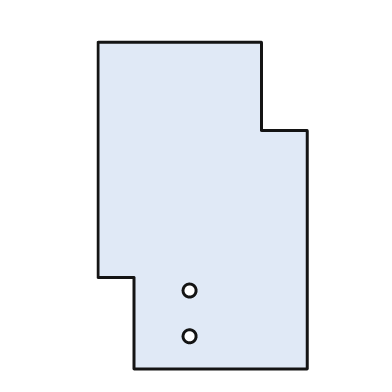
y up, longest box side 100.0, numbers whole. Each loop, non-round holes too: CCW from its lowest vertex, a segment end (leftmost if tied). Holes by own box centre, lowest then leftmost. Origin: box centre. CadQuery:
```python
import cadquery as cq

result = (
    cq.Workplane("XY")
    .moveTo(-21.0, -50.0)
    .lineTo(32.0, -50.0)
    .lineTo(32.0, 23.0)
    .lineTo(18.0, 23.0)
    .lineTo(18.0, 50.0)
    .lineTo(-32.0, 50.0)
    .lineTo(-32.0, -22.0)
    .lineTo(-21.0, -22.0)
    .close()
    .moveTo(-4.0, -40.0)
    .circle(2.0)
    .moveTo(-4.0, -26.0)
    .circle(2.0)
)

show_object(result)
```